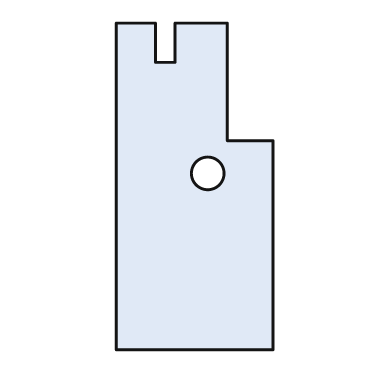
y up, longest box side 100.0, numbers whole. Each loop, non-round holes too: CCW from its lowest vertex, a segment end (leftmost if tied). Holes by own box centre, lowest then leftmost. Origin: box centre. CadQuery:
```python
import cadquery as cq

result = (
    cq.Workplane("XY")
    .moveTo(-24.0, -50.0)
    .lineTo(24.0, -50.0)
    .lineTo(24.0, 14.0)
    .lineTo(10.0, 14.0)
    .lineTo(10.0, 50.0)
    .lineTo(-6.0, 50.0)
    .lineTo(-6.0, 38.0)
    .lineTo(-12.0, 38.0)
    .lineTo(-12.0, 50.0)
    .lineTo(-24.0, 50.0)
    .close()
    .moveTo(4.0, 4.0)
    .circle(5.0)
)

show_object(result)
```